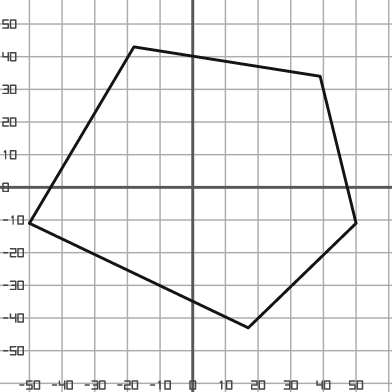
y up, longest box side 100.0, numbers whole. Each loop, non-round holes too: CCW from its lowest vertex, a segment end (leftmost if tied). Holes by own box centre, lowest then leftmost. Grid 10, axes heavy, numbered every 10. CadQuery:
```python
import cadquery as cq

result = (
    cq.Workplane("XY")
    .moveTo(17.0, -43.0)
    .lineTo(50.0, -11.0)
    .lineTo(39.0, 34.0)
    .lineTo(-18.0, 43.0)
    .lineTo(-50.0, -11.0)
    .close()
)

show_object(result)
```